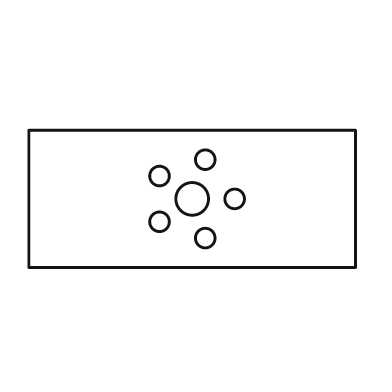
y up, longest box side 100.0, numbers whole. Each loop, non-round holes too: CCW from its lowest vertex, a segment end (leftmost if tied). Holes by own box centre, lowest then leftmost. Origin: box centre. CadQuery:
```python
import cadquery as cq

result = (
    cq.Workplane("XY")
    .moveTo(-50.0, -21.0)
    .lineTo(50.0, -21.0)
    .lineTo(50.0, 21.0)
    .lineTo(-50.0, 21.0)
    .close()
    .moveTo(4.0, -12.0)
    .circle(3.0)
    .moveTo(-10.0, -7.0)
    .circle(3.0)
    .moveTo(0.0, 0.0)
    .circle(5.0)
    .moveTo(13.0, 0.0)
    .circle(3.0)
    .moveTo(-10.0, 7.0)
    .circle(3.0)
    .moveTo(4.0, 12.0)
    .circle(3.0)
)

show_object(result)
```